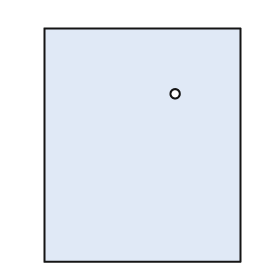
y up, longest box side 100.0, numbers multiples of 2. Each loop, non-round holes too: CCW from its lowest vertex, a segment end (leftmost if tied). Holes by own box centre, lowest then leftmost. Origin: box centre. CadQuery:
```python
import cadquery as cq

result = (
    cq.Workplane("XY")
    .moveTo(-42.0, -50.0)
    .lineTo(42.0, -50.0)
    .lineTo(42.0, 50.0)
    .lineTo(-42.0, 50.0)
    .close()
    .moveTo(14.0, 22.0)
    .circle(2.0)
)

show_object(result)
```